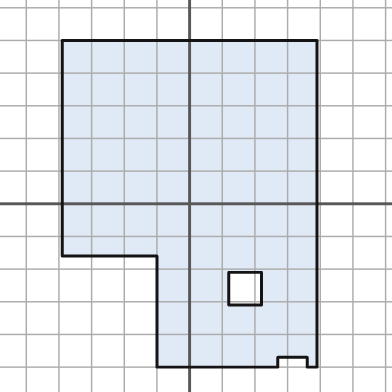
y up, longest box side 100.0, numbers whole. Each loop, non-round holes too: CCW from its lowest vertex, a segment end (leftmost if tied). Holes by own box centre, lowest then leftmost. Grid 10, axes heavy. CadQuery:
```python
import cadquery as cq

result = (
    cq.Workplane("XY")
    .moveTo(-10.0, -50.0)
    .lineTo(27.0, -50.0)
    .lineTo(27.0, -47.0)
    .lineTo(36.0, -47.0)
    .lineTo(36.0, -50.0)
    .lineTo(39.0, -50.0)
    .lineTo(39.0, 50.0)
    .lineTo(-39.0, 50.0)
    .lineTo(-39.0, -16.0)
    .lineTo(-10.0, -16.0)
    .close()
    .moveTo(12.0, -31.0)
    .lineTo(22.0, -31.0)
    .lineTo(22.0, -21.0)
    .lineTo(12.0, -21.0)
    .close()
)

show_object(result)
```